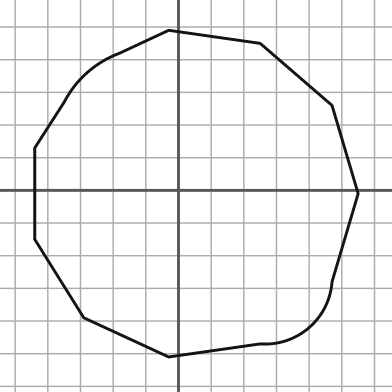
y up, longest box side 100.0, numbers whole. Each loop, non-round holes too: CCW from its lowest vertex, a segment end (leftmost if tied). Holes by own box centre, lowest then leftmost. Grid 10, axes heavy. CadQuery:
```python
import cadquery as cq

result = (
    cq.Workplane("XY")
    .moveTo(-3.0, -51.0)
    .lineTo(25.0, -47.0)
    .threePointArc((40.0, -42.0), (47.0, -28.0))
    .lineTo(55.0, -1.0)
    .lineTo(47.0, 26.0)
    .lineTo(25.0, 45.0)
    .lineTo(-3.0, 49.0)
    .lineTo(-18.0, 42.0)
    .threePointArc((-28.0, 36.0), (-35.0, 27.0))
    .lineTo(-44.0, 13.0)
    .lineTo(-44.0, -15.0)
    .lineTo(-29.0, -39.0)
    .close()
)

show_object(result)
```